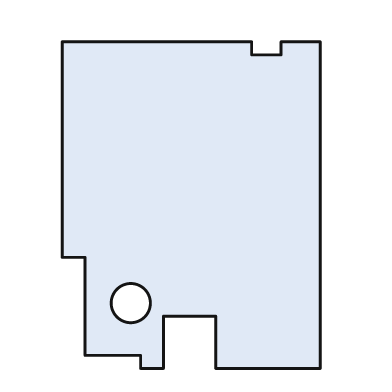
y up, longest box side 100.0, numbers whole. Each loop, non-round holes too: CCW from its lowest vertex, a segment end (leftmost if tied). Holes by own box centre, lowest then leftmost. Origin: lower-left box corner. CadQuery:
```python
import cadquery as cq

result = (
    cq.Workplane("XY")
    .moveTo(24.0, 0.0)
    .lineTo(31.0, 0.0)
    .lineTo(31.0, 16.0)
    .lineTo(47.0, 16.0)
    .lineTo(47.0, 0.0)
    .lineTo(79.0, 0.0)
    .lineTo(79.0, 100.0)
    .lineTo(67.0, 100.0)
    .lineTo(67.0, 96.0)
    .lineTo(58.0, 96.0)
    .lineTo(58.0, 100.0)
    .lineTo(0.0, 100.0)
    .lineTo(0.0, 34.0)
    .lineTo(7.0, 34.0)
    .lineTo(7.0, 4.0)
    .lineTo(24.0, 4.0)
    .close()
    .moveTo(21.0, 20.0)
    .circle(6.0)
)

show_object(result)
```